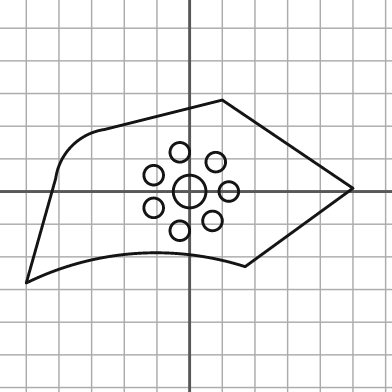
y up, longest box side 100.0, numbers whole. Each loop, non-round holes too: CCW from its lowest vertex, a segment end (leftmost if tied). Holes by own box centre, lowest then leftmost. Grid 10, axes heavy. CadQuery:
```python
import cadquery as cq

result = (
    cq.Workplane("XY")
    .moveTo(-50.0, -28.0)
    .threePointArc((-17.0, -19.0), (17.0, -23.0))
    .lineTo(50.0, 1.0)
    .lineTo(10.0, 28.0)
    .lineTo(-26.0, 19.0)
    .threePointArc((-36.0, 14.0), (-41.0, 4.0))
    .close()
    .moveTo(-3.0, -12.0)
    .circle(3.0)
    .moveTo(7.0, -9.0)
    .circle(3.0)
    .moveTo(-11.0, -5.0)
    .circle(3.0)
    .moveTo(0.0, 0.0)
    .circle(5.0)
    .moveTo(12.0, 0.0)
    .circle(3.0)
    .moveTo(-11.0, 5.0)
    .circle(3.0)
    .moveTo(8.0, 9.0)
    .circle(3.0)
    .moveTo(-3.0, 12.0)
    .circle(3.0)
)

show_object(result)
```